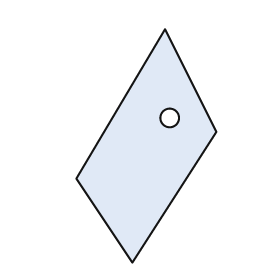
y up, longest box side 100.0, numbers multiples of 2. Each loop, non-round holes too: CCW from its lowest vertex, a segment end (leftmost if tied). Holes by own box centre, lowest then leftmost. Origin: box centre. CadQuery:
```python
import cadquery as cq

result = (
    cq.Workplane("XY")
    .moveTo(-6.0, -50.0)
    .lineTo(30.0, 6.0)
    .lineTo(8.0, 50.0)
    .lineTo(-30.0, -14.0)
    .close()
    .moveTo(10.0, 12.0)
    .circle(4.0)
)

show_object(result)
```